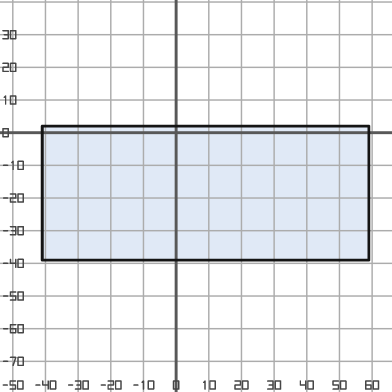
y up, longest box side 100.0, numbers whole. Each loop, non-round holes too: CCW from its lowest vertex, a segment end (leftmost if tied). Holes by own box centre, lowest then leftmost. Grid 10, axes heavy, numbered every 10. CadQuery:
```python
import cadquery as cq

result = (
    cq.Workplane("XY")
    .moveTo(-41.0, -39.0)
    .lineTo(59.0, -39.0)
    .lineTo(59.0, 2.0)
    .lineTo(-41.0, 2.0)
    .close()
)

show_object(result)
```